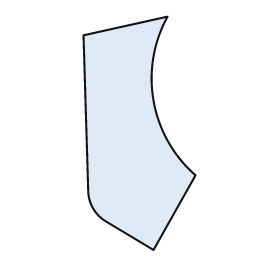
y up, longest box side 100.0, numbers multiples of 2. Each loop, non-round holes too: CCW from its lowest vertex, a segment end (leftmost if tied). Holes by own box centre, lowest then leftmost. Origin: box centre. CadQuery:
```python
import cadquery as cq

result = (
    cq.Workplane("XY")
    .moveTo(6.0, -50.0)
    .lineTo(24.0, -18.0)
    .threePointArc((6.0, 14.0), (12.0, 50.0))
    .lineTo(-24.0, 42.0)
    .lineTo(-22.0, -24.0)
    .threePointArc((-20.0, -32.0), (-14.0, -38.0))
    .close()
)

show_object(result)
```